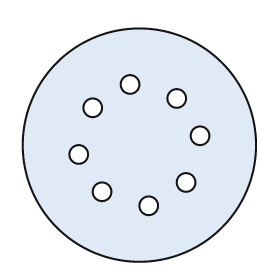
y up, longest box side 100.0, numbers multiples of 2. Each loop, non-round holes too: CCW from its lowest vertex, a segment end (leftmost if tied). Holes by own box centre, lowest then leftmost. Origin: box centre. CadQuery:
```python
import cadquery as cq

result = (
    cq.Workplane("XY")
    .moveTo(0.0, 0.0)
    .circle(50.0)
    .moveTo(4.0, -26.0)
    .circle(4.0)
    .moveTo(-16.0, -20.0)
    .circle(4.0)
    .moveTo(20.0, -16.0)
    .circle(4.0)
    .moveTo(-26.0, -4.0)
    .circle(4.0)
    .moveTo(26.0, 4.0)
    .circle(4.0)
    .moveTo(-20.0, 16.0)
    .circle(4.0)
    .moveTo(16.0, 20.0)
    .circle(4.0)
    .moveTo(-4.0, 26.0)
    .circle(4.0)
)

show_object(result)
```